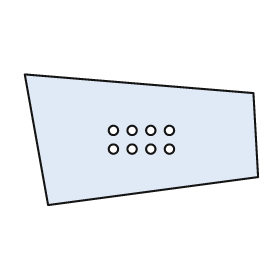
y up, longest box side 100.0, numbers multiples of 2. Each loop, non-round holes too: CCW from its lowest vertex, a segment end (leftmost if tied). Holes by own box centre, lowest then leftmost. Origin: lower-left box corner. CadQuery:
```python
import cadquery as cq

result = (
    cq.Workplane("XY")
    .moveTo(10.0, 0.0)
    .lineTo(100.0, 12.0)
    .lineTo(98.0, 48.0)
    .lineTo(0.0, 56.0)
    .close()
    .moveTo(38.0, 24.0)
    .circle(2.0)
    .moveTo(46.0, 24.0)
    .circle(2.0)
    .moveTo(54.0, 24.0)
    .circle(2.0)
    .moveTo(62.0, 24.0)
    .circle(2.0)
    .moveTo(38.0, 32.0)
    .circle(2.0)
    .moveTo(46.0, 32.0)
    .circle(2.0)
    .moveTo(54.0, 32.0)
    .circle(2.0)
    .moveTo(62.0, 32.0)
    .circle(2.0)
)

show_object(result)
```